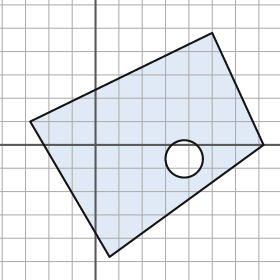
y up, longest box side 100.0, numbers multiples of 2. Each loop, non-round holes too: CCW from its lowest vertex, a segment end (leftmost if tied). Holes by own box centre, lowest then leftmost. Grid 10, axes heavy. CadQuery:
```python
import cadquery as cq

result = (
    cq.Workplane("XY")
    .moveTo(6.0, -48.0)
    .lineTo(72.0, 0.0)
    .lineTo(50.0, 48.0)
    .lineTo(-28.0, 10.0)
    .close()
    .moveTo(38.0, -6.0)
    .circle(8.0)
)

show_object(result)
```